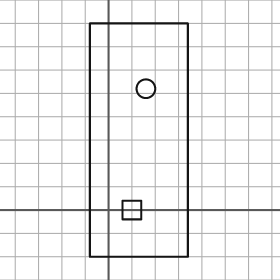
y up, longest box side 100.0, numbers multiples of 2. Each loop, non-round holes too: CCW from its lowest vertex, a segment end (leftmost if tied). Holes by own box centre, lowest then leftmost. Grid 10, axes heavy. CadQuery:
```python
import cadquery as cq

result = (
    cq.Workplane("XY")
    .moveTo(-8.0, -20.0)
    .lineTo(34.0, -20.0)
    .lineTo(34.0, 80.0)
    .lineTo(-8.0, 80.0)
    .close()
    .moveTo(6.0, -4.0)
    .lineTo(14.0, -4.0)
    .lineTo(14.0, 4.0)
    .lineTo(6.0, 4.0)
    .close()
    .moveTo(16.0, 52.0)
    .circle(4.0)
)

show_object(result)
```